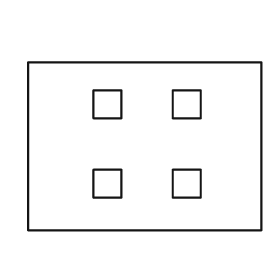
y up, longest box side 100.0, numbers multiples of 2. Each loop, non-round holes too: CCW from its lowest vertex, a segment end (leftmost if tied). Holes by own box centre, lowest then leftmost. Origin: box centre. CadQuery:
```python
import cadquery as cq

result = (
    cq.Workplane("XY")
    .moveTo(-50.0, -36.0)
    .lineTo(50.0, -36.0)
    .lineTo(50.0, 36.0)
    .lineTo(-50.0, 36.0)
    .close()
    .moveTo(-22.0, -22.0)
    .lineTo(-10.0, -22.0)
    .lineTo(-10.0, -10.0)
    .lineTo(-22.0, -10.0)
    .close()
    .moveTo(12.0, -22.0)
    .lineTo(24.0, -22.0)
    .lineTo(24.0, -10.0)
    .lineTo(12.0, -10.0)
    .close()
    .moveTo(-22.0, 12.0)
    .lineTo(-10.0, 12.0)
    .lineTo(-10.0, 24.0)
    .lineTo(-22.0, 24.0)
    .close()
    .moveTo(12.0, 12.0)
    .lineTo(24.0, 12.0)
    .lineTo(24.0, 24.0)
    .lineTo(12.0, 24.0)
    .close()
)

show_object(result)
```